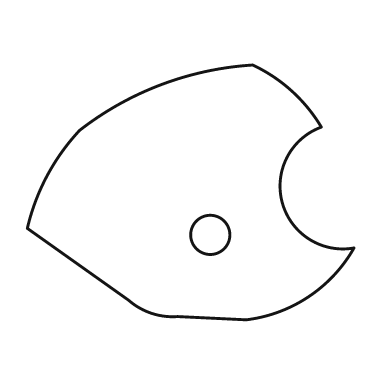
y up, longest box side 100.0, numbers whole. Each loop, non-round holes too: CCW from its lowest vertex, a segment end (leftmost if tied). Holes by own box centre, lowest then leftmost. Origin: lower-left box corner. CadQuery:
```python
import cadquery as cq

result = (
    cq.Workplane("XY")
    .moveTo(67.0, 0.0)
    .threePointArc((86.0, 7.0), (100.0, 22.0))
    .threePointArc((78.0, 36.0), (90.0, 59.0))
    .threePointArc((81.0, 70.0), (69.0, 78.0))
    .threePointArc((41.0, 72.0), (16.0, 58.0))
    .threePointArc((6.0, 44.0), (0.0, 28.0))
    .lineTo(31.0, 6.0)
    .threePointArc((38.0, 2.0), (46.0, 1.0))
    .close()
    .moveTo(56.0, 26.0)
    .circle(6.0)
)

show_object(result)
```